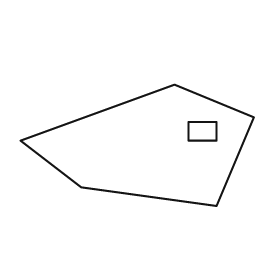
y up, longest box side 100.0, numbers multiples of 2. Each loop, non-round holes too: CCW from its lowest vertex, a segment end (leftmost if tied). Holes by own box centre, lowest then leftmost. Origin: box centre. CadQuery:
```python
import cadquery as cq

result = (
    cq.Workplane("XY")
    .moveTo(34.0, -26.0)
    .lineTo(50.0, 12.0)
    .lineTo(16.0, 26.0)
    .lineTo(-50.0, 2.0)
    .lineTo(-24.0, -18.0)
    .close()
    .moveTo(22.0, 2.0)
    .lineTo(34.0, 2.0)
    .lineTo(34.0, 10.0)
    .lineTo(22.0, 10.0)
    .close()
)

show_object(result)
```